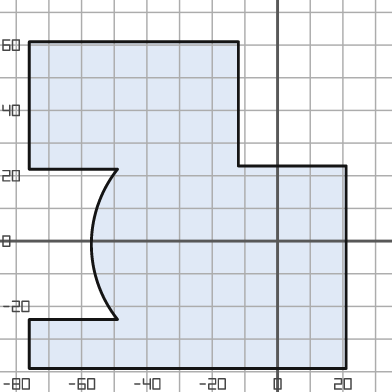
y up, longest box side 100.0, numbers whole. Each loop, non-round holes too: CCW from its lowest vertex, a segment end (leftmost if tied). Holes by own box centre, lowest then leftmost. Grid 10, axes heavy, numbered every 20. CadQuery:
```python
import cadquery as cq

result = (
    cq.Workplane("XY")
    .moveTo(-76.0, -39.0)
    .lineTo(21.0, -39.0)
    .lineTo(21.0, 23.0)
    .lineTo(-12.0, 23.0)
    .lineTo(-12.0, 61.0)
    .lineTo(-76.0, 61.0)
    .lineTo(-76.0, 22.0)
    .lineTo(-49.0, 22.0)
    .threePointArc((-57.0, -1.0), (-49.0, -24.0))
    .lineTo(-76.0, -24.0)
    .close()
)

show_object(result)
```